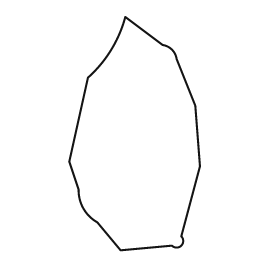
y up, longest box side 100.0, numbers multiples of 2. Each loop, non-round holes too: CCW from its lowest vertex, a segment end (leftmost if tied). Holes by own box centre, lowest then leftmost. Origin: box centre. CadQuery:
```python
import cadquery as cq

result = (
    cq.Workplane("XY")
    .moveTo(-6.0, -50.0)
    .lineTo(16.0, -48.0)
    .threePointArc((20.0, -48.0), (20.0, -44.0))
    .lineTo(28.0, -14.0)
    .lineTo(26.0, 12.0)
    .lineTo(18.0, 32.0)
    .threePointArc((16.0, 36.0), (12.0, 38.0))
    .lineTo(-4.0, 50.0)
    .threePointArc((-10.0, 36.0), (-20.0, 24.0))
    .lineTo(-28.0, -12.0)
    .lineTo(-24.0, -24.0)
    .threePointArc((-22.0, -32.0), (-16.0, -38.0))
    .close()
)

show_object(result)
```